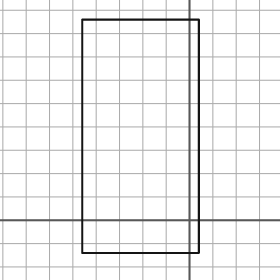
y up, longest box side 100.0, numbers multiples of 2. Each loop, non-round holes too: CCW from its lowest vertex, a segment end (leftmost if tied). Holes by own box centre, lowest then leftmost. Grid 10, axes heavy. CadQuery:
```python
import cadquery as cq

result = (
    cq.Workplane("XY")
    .moveTo(-46.0, -14.0)
    .lineTo(4.0, -14.0)
    .lineTo(4.0, 86.0)
    .lineTo(-46.0, 86.0)
    .close()
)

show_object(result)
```